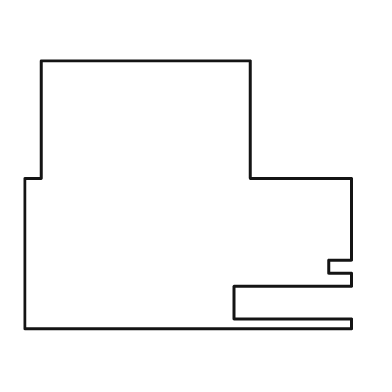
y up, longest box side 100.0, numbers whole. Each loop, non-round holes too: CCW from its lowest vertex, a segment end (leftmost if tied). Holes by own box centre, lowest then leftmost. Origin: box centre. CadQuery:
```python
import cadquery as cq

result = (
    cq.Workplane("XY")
    .moveTo(-50.0, -41.0)
    .lineTo(50.0, -41.0)
    .lineTo(50.0, -38.0)
    .lineTo(14.0, -38.0)
    .lineTo(14.0, -28.0)
    .lineTo(50.0, -28.0)
    .lineTo(50.0, -24.0)
    .lineTo(43.0, -24.0)
    .lineTo(43.0, -20.0)
    .lineTo(50.0, -20.0)
    .lineTo(50.0, 5.0)
    .lineTo(19.0, 5.0)
    .lineTo(19.0, 41.0)
    .lineTo(-45.0, 41.0)
    .lineTo(-45.0, 5.0)
    .lineTo(-50.0, 5.0)
    .close()
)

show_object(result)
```